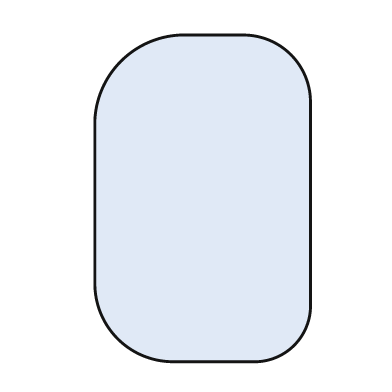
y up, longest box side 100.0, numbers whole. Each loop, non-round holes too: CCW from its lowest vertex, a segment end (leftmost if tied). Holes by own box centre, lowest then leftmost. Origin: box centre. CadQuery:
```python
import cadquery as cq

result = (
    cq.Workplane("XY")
    .moveTo(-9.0, -50.0)
    .lineTo(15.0, -50.0)
    .threePointArc((28.0, -45.0), (33.0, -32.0))
    .lineTo(33.0, 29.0)
    .threePointArc((27.0, 44.0), (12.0, 50.0))
    .lineTo(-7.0, 50.0)
    .threePointArc((-25.0, 42.0), (-33.0, 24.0))
    .lineTo(-33.0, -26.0)
    .threePointArc((-26.0, -43.0), (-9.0, -50.0))
    .close()
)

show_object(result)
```